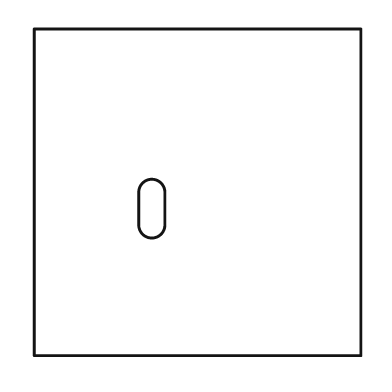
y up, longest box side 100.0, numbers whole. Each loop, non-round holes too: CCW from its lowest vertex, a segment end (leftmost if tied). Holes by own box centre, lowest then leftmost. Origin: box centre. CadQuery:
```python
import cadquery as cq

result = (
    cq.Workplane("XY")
    .moveTo(-50.0, -50.0)
    .lineTo(50.0, -50.0)
    .lineTo(50.0, 50.0)
    .lineTo(-50.0, 50.0)
    .close()
    .moveTo(-18.0, -10.0)
    .threePointArc((-14.0, -14.0), (-10.0, -10.0))
    .lineTo(-10.0, 0.0)
    .threePointArc((-14.0, 4.0), (-18.0, 0.0))
    .close()
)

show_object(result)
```